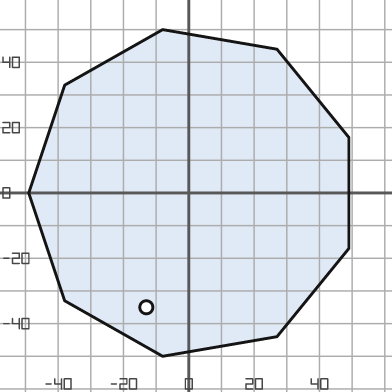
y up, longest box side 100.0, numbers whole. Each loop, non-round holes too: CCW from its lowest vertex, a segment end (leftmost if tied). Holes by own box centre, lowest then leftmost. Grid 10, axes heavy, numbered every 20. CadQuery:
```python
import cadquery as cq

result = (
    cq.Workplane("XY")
    .moveTo(-8.0, -50.0)
    .lineTo(27.0, -44.0)
    .lineTo(49.0, -17.0)
    .lineTo(49.0, 17.0)
    .lineTo(27.0, 44.0)
    .lineTo(-8.0, 50.0)
    .lineTo(-38.0, 33.0)
    .lineTo(-49.0, 0.0)
    .lineTo(-38.0, -33.0)
    .close()
    .moveTo(-13.0, -35.0)
    .circle(2.0)
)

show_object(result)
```